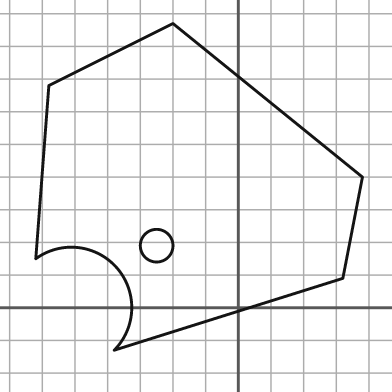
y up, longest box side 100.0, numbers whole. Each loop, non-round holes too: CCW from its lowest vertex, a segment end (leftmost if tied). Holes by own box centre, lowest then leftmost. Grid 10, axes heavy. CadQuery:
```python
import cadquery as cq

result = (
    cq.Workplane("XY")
    .moveTo(-38.0, -13.0)
    .lineTo(32.0, 9.0)
    .lineTo(38.0, 40.0)
    .lineTo(-20.0, 87.0)
    .lineTo(-58.0, 68.0)
    .lineTo(-62.0, 15.0)
    .threePointArc((-37.0, 12.0), (-38.0, -13.0))
    .close()
    .moveTo(-25.0, 19.0)
    .circle(5.0)
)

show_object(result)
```